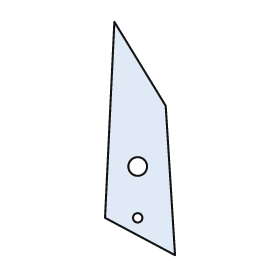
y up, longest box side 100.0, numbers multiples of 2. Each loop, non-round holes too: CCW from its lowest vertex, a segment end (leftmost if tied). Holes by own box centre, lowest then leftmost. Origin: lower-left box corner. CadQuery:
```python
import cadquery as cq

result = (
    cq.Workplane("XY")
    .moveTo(30.0, 0.0)
    .lineTo(26.0, 64.0)
    .lineTo(4.0, 100.0)
    .lineTo(0.0, 16.0)
    .close()
    .moveTo(14.0, 16.0)
    .circle(2.0)
    .moveTo(14.0, 38.0)
    .circle(4.0)
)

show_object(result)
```